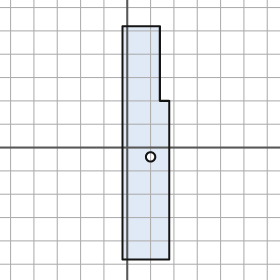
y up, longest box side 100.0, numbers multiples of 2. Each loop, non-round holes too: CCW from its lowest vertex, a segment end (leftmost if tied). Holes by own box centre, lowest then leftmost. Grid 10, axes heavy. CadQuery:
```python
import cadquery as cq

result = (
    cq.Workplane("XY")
    .moveTo(-2.0, -48.0)
    .lineTo(18.0, -48.0)
    .lineTo(18.0, 20.0)
    .lineTo(14.0, 20.0)
    .lineTo(14.0, 52.0)
    .lineTo(-2.0, 52.0)
    .close()
    .moveTo(10.0, -4.0)
    .circle(2.0)
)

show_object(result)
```